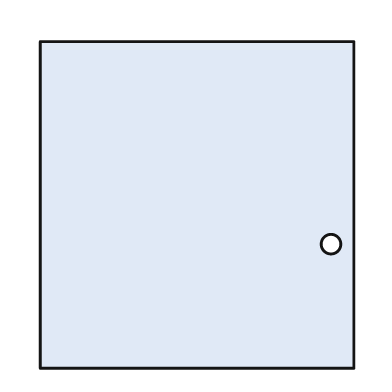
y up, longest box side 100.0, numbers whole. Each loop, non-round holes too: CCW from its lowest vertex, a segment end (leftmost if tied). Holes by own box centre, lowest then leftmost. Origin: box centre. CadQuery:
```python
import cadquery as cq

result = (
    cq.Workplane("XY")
    .moveTo(-48.0, -50.0)
    .lineTo(48.0, -50.0)
    .lineTo(48.0, 50.0)
    .lineTo(-48.0, 50.0)
    .close()
    .moveTo(41.0, -12.0)
    .circle(3.0)
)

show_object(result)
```